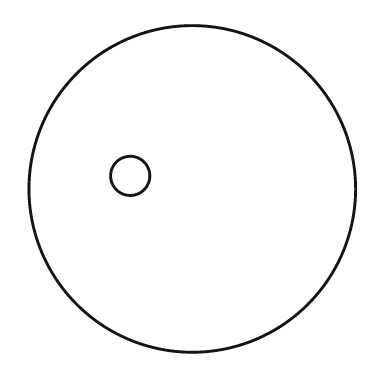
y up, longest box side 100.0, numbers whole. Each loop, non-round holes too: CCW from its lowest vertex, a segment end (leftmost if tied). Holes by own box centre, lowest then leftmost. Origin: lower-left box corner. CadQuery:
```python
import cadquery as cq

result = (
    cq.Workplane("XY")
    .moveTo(50.0, 50.0)
    .circle(50.0)
    .moveTo(31.0, 54.0)
    .circle(6.0)
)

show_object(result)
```